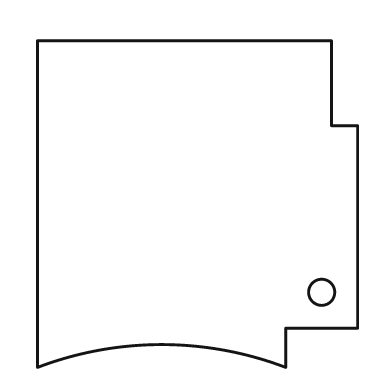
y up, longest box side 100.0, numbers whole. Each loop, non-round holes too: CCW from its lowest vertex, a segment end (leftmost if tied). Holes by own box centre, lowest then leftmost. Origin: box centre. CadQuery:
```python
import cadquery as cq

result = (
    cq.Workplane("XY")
    .moveTo(-49.0, -50.0)
    .threePointArc((-11.0, -43.0), (27.0, -50.0))
    .lineTo(27.0, -38.0)
    .lineTo(49.0, -38.0)
    .lineTo(49.0, 24.0)
    .lineTo(41.0, 24.0)
    .lineTo(41.0, 50.0)
    .lineTo(-49.0, 50.0)
    .close()
    .moveTo(38.0, -27.0)
    .circle(4.0)
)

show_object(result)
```